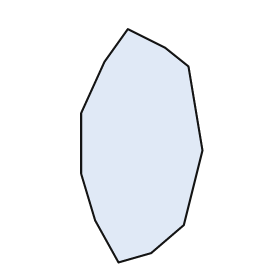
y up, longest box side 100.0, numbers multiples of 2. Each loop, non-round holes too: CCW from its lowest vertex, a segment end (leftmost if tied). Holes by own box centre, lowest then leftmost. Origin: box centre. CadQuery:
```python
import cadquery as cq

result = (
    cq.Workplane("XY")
    .moveTo(-10.0, -50.0)
    .lineTo(4.0, -46.0)
    .lineTo(18.0, -34.0)
    .lineTo(26.0, -2.0)
    .lineTo(20.0, 34.0)
    .lineTo(10.0, 42.0)
    .lineTo(-6.0, 50.0)
    .lineTo(-16.0, 36.0)
    .lineTo(-26.0, 14.0)
    .lineTo(-26.0, -12.0)
    .lineTo(-20.0, -32.0)
    .close()
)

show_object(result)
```